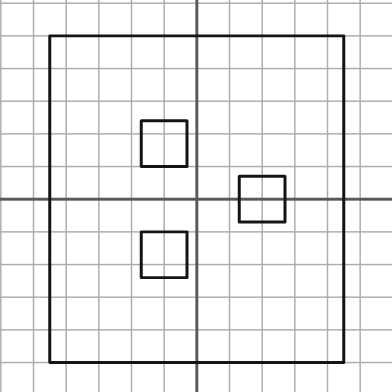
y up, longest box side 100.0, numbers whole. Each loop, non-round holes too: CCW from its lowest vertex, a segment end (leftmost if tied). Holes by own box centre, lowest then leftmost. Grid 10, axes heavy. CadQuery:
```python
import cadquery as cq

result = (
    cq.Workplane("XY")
    .moveTo(-45.0, -50.0)
    .lineTo(45.0, -50.0)
    .lineTo(45.0, 50.0)
    .lineTo(-45.0, 50.0)
    .close()
    .moveTo(-17.0, -24.0)
    .lineTo(-3.0, -24.0)
    .lineTo(-3.0, -10.0)
    .lineTo(-17.0, -10.0)
    .close()
    .moveTo(13.0, -7.0)
    .lineTo(27.0, -7.0)
    .lineTo(27.0, 7.0)
    .lineTo(13.0, 7.0)
    .close()
    .moveTo(-17.0, 10.0)
    .lineTo(-3.0, 10.0)
    .lineTo(-3.0, 24.0)
    .lineTo(-17.0, 24.0)
    .close()
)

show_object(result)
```